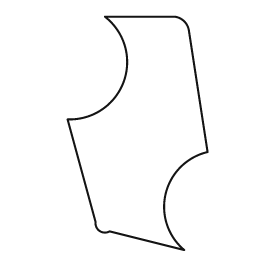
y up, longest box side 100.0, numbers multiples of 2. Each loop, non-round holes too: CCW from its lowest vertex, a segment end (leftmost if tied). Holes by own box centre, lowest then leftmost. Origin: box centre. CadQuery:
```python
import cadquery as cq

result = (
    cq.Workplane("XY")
    .moveTo(20.0, -50.0)
    .threePointArc((12.0, -26.0), (30.0, -8.0))
    .lineTo(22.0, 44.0)
    .threePointArc((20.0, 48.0), (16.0, 50.0))
    .lineTo(-14.0, 50.0)
    .threePointArc((-6.0, 22.0), (-30.0, 6.0))
    .lineTo(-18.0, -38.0)
    .threePointArc((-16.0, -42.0), (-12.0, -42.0))
    .close()
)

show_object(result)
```